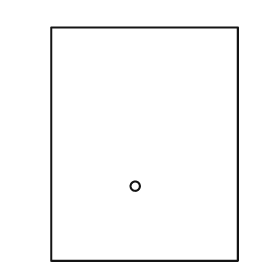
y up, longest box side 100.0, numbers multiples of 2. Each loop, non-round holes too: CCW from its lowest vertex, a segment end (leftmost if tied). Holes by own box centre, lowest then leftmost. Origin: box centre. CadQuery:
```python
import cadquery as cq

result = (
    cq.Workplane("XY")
    .moveTo(-40.0, -50.0)
    .lineTo(40.0, -50.0)
    .lineTo(40.0, 50.0)
    .lineTo(-40.0, 50.0)
    .close()
    .moveTo(-4.0, -18.0)
    .circle(2.0)
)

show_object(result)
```